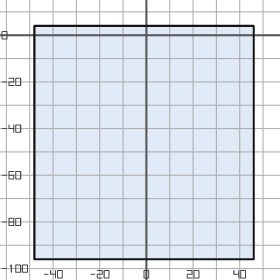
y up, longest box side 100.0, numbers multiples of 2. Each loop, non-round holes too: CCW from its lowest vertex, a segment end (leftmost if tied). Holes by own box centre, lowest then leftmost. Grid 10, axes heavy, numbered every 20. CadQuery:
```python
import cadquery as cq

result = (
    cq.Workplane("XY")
    .moveTo(-48.0, -96.0)
    .lineTo(46.0, -96.0)
    .lineTo(46.0, 4.0)
    .lineTo(-48.0, 4.0)
    .close()
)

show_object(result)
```